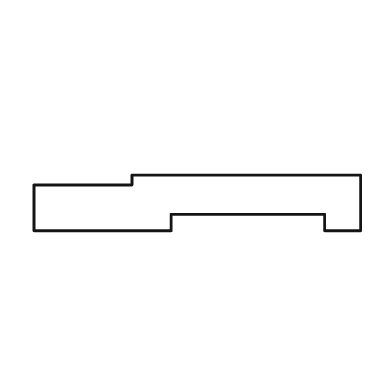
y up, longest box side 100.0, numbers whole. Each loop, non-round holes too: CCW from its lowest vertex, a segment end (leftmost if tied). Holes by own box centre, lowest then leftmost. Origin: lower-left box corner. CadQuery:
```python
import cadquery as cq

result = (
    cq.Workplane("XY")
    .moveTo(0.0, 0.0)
    .lineTo(42.0, 0.0)
    .lineTo(42.0, 5.0)
    .lineTo(89.0, 5.0)
    .lineTo(89.0, 0.0)
    .lineTo(100.0, 0.0)
    .lineTo(100.0, 17.0)
    .lineTo(30.0, 17.0)
    .lineTo(30.0, 14.0)
    .lineTo(0.0, 14.0)
    .close()
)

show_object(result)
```